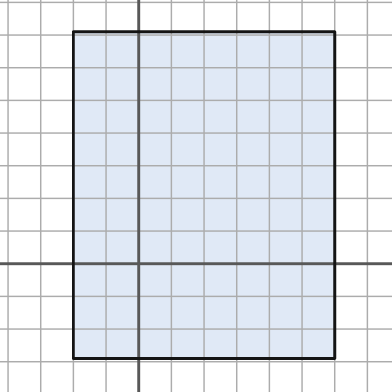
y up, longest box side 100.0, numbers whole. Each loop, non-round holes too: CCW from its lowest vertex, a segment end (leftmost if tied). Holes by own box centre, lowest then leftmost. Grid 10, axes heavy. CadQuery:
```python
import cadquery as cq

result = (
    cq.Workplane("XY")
    .moveTo(-20.0, -29.0)
    .lineTo(60.0, -29.0)
    .lineTo(60.0, 71.0)
    .lineTo(-20.0, 71.0)
    .close()
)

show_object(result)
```